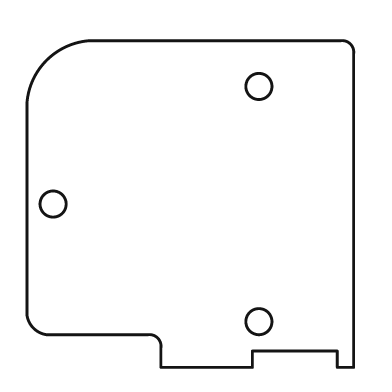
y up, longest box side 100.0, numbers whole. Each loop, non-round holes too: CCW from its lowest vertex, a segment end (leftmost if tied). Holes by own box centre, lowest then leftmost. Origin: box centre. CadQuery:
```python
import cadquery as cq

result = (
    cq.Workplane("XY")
    .moveTo(-9.0, -50.0)
    .lineTo(19.0, -50.0)
    .lineTo(19.0, -45.0)
    .lineTo(45.0, -45.0)
    .lineTo(45.0, -50.0)
    .lineTo(50.0, -50.0)
    .lineTo(50.0, 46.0)
    .threePointArc((49.0, 49.0), (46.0, 50.0))
    .lineTo(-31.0, 50.0)
    .threePointArc((-44.0, 44.0), (-50.0, 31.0))
    .lineTo(-50.0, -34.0)
    .threePointArc((-48.0, -38.0), (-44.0, -40.0))
    .lineTo(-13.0, -40.0)
    .threePointArc((-10.0, -41.0), (-9.0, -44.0))
    .close()
    .moveTo(21.0, -36.0)
    .circle(4.0)
    .moveTo(-42.0, 0.0)
    .circle(4.0)
    .moveTo(21.0, 36.0)
    .circle(4.0)
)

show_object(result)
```